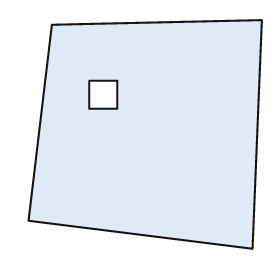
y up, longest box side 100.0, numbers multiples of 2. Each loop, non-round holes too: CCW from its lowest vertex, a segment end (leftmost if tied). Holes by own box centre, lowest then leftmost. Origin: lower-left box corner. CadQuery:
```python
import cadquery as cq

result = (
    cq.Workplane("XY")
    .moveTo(96.0, 0.0)
    .lineTo(100.0, 98.0)
    .lineTo(10.0, 96.0)
    .lineTo(0.0, 12.0)
    .close()
    .moveTo(26.0, 60.0)
    .lineTo(38.0, 60.0)
    .lineTo(38.0, 72.0)
    .lineTo(26.0, 72.0)
    .close()
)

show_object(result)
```